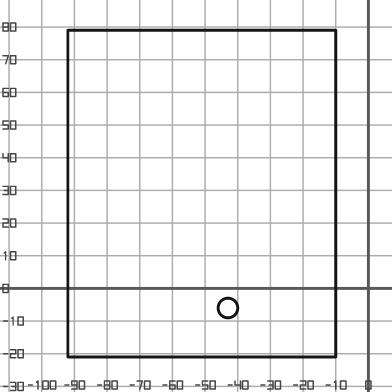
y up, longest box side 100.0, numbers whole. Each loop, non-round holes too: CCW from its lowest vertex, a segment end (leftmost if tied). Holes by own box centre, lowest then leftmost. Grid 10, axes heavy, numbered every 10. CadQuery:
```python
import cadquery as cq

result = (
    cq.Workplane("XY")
    .moveTo(-92.0, -21.0)
    .lineTo(-10.0, -21.0)
    .lineTo(-10.0, 79.0)
    .lineTo(-92.0, 79.0)
    .close()
    .moveTo(-43.0, -6.0)
    .circle(3.0)
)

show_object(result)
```